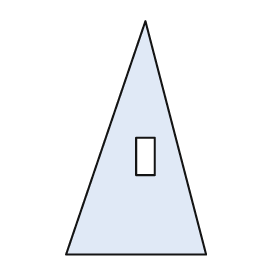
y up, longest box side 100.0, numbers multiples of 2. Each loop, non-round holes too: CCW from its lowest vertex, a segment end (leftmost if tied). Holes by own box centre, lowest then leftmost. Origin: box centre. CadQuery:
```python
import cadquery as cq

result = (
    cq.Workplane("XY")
    .moveTo(-30.0, -50.0)
    .lineTo(30.0, -50.0)
    .lineTo(4.0, 50.0)
    .close()
    .moveTo(0.0, -16.0)
    .lineTo(8.0, -16.0)
    .lineTo(8.0, 0.0)
    .lineTo(0.0, 0.0)
    .close()
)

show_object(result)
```